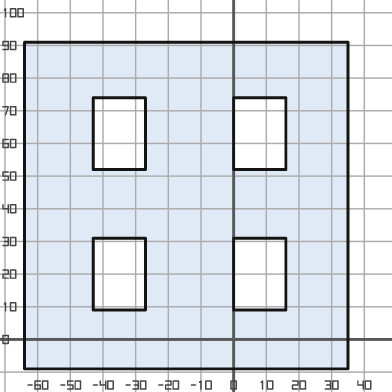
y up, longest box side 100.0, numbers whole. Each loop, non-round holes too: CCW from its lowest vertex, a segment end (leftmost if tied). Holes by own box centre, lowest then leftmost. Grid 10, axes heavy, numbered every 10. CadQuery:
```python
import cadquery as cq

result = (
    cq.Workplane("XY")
    .moveTo(-64.0, -9.0)
    .lineTo(35.0, -9.0)
    .lineTo(35.0, 91.0)
    .lineTo(-64.0, 91.0)
    .close()
    .moveTo(-43.0, 9.0)
    .lineTo(-27.0, 9.0)
    .lineTo(-27.0, 31.0)
    .lineTo(-43.0, 31.0)
    .close()
    .moveTo(0.0, 9.0)
    .lineTo(16.0, 9.0)
    .lineTo(16.0, 31.0)
    .lineTo(0.0, 31.0)
    .close()
    .moveTo(-43.0, 52.0)
    .lineTo(-27.0, 52.0)
    .lineTo(-27.0, 74.0)
    .lineTo(-43.0, 74.0)
    .close()
    .moveTo(0.0, 52.0)
    .lineTo(16.0, 52.0)
    .lineTo(16.0, 74.0)
    .lineTo(0.0, 74.0)
    .close()
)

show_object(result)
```